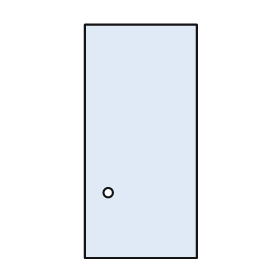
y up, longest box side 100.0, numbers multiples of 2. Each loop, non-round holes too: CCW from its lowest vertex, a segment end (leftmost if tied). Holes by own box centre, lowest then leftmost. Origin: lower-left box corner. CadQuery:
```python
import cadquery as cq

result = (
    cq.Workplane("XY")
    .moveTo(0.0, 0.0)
    .lineTo(48.0, 0.0)
    .lineTo(48.0, 100.0)
    .lineTo(0.0, 100.0)
    .close()
    .moveTo(10.0, 28.0)
    .circle(2.0)
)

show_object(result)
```